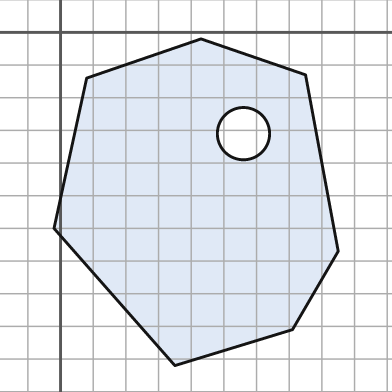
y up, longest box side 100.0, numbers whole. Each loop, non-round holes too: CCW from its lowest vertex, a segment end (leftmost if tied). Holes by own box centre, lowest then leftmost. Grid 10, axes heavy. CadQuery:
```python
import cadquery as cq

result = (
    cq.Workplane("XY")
    .moveTo(35.0, -102.0)
    .lineTo(71.0, -91.0)
    .lineTo(85.0, -67.0)
    .lineTo(75.0, -13.0)
    .lineTo(43.0, -2.0)
    .lineTo(8.0, -14.0)
    .lineTo(-2.0, -60.0)
    .close()
    .moveTo(56.0, -31.0)
    .circle(8.0)
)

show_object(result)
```